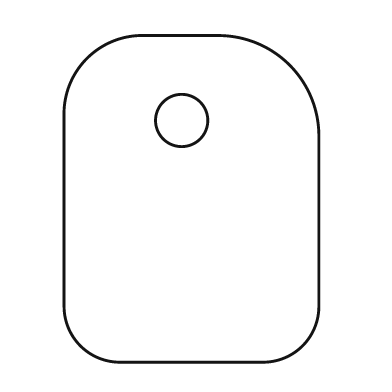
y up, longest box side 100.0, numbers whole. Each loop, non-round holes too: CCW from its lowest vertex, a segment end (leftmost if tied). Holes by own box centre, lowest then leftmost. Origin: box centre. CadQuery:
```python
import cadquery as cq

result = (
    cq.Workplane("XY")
    .moveTo(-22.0, -50.0)
    .lineTo(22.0, -50.0)
    .threePointArc((34.0, -45.0), (39.0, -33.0))
    .lineTo(39.0, 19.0)
    .threePointArc((30.0, 41.0), (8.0, 50.0))
    .lineTo(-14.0, 50.0)
    .threePointArc((-32.0, 43.0), (-39.0, 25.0))
    .lineTo(-39.0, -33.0)
    .threePointArc((-34.0, -45.0), (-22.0, -50.0))
    .close()
    .moveTo(-3.0, 24.0)
    .circle(8.0)
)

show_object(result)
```